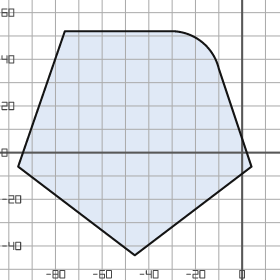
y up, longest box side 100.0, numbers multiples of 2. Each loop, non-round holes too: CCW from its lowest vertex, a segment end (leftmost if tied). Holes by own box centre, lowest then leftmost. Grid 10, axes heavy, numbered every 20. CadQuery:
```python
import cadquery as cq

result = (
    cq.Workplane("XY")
    .moveTo(-46.0, -44.0)
    .lineTo(4.0, -6.0)
    .lineTo(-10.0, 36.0)
    .threePointArc((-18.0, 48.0), (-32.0, 52.0))
    .lineTo(-76.0, 52.0)
    .lineTo(-96.0, -6.0)
    .close()
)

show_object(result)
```